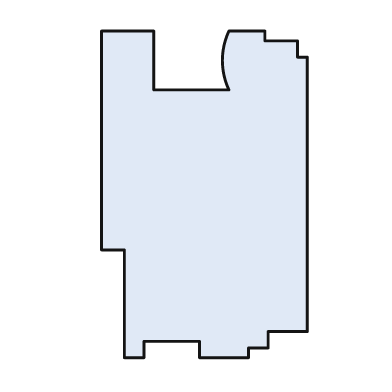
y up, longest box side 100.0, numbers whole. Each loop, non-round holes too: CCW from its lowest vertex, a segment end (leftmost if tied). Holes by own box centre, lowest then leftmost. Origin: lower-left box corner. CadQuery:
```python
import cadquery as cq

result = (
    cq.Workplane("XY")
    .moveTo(7.0, 0.0)
    .lineTo(13.0, 0.0)
    .lineTo(13.0, 5.0)
    .lineTo(30.0, 5.0)
    .lineTo(30.0, 0.0)
    .lineTo(45.0, 0.0)
    .lineTo(45.0, 3.0)
    .lineTo(51.0, 3.0)
    .lineTo(51.0, 8.0)
    .lineTo(63.0, 8.0)
    .lineTo(63.0, 92.0)
    .lineTo(60.0, 92.0)
    .lineTo(60.0, 97.0)
    .lineTo(50.0, 97.0)
    .lineTo(50.0, 100.0)
    .lineTo(39.0, 100.0)
    .threePointArc((37.0, 91.0), (39.0, 82.0))
    .lineTo(16.0, 82.0)
    .lineTo(16.0, 100.0)
    .lineTo(0.0, 100.0)
    .lineTo(0.0, 33.0)
    .lineTo(7.0, 33.0)
    .close()
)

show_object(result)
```